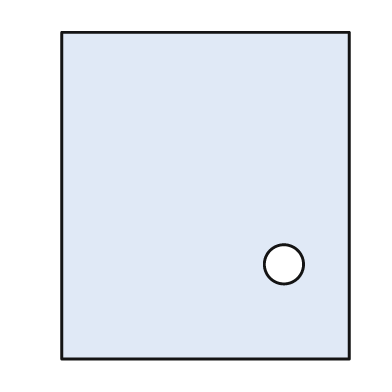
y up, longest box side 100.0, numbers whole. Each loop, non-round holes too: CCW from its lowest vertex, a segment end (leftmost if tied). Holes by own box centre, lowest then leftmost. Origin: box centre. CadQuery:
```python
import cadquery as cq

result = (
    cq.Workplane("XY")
    .moveTo(-44.0, -50.0)
    .lineTo(44.0, -50.0)
    .lineTo(44.0, 50.0)
    .lineTo(-44.0, 50.0)
    .close()
    .moveTo(24.0, -21.0)
    .circle(6.0)
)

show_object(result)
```